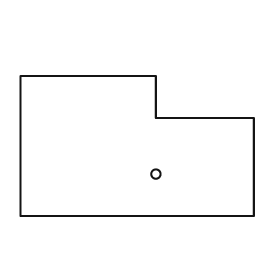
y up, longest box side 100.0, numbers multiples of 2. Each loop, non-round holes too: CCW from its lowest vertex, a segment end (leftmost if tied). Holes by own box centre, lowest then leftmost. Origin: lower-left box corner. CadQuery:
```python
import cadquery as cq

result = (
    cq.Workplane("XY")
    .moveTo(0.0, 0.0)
    .lineTo(100.0, 0.0)
    .lineTo(100.0, 42.0)
    .lineTo(58.0, 42.0)
    .lineTo(58.0, 60.0)
    .lineTo(0.0, 60.0)
    .close()
    .moveTo(58.0, 18.0)
    .circle(2.0)
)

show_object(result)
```